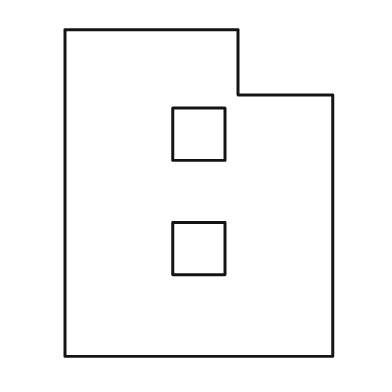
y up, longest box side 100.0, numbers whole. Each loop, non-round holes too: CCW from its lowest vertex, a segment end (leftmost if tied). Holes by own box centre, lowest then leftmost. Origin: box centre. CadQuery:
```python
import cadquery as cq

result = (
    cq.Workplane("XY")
    .moveTo(-41.0, -50.0)
    .lineTo(41.0, -50.0)
    .lineTo(41.0, 30.0)
    .lineTo(12.0, 30.0)
    .lineTo(12.0, 50.0)
    .lineTo(-41.0, 50.0)
    .close()
    .moveTo(-8.0, -25.0)
    .lineTo(8.0, -25.0)
    .lineTo(8.0, -9.0)
    .lineTo(-8.0, -9.0)
    .close()
    .moveTo(-8.0, 10.0)
    .lineTo(8.0, 10.0)
    .lineTo(8.0, 26.0)
    .lineTo(-8.0, 26.0)
    .close()
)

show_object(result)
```